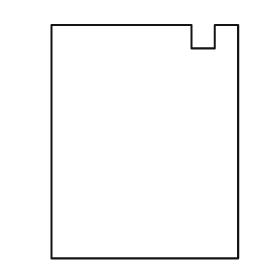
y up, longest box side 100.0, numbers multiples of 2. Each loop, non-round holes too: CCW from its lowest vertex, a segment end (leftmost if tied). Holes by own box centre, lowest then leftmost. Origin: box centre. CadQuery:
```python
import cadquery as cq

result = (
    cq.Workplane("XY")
    .moveTo(-40.0, -50.0)
    .lineTo(40.0, -50.0)
    .lineTo(40.0, 50.0)
    .lineTo(30.0, 50.0)
    .lineTo(30.0, 40.0)
    .lineTo(20.0, 40.0)
    .lineTo(20.0, 50.0)
    .lineTo(-40.0, 50.0)
    .close()
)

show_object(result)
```